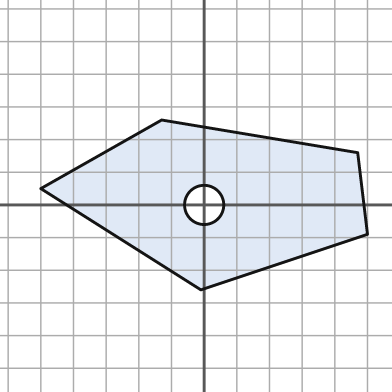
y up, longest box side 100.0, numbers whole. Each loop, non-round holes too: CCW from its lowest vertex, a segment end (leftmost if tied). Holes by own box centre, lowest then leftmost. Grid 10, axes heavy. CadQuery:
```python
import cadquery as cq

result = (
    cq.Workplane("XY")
    .moveTo(-1.0, -26.0)
    .lineTo(50.0, -9.0)
    .lineTo(47.0, 16.0)
    .lineTo(-13.0, 26.0)
    .lineTo(-50.0, 5.0)
    .close()
    .moveTo(0.0, 0.0)
    .circle(6.0)
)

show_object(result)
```